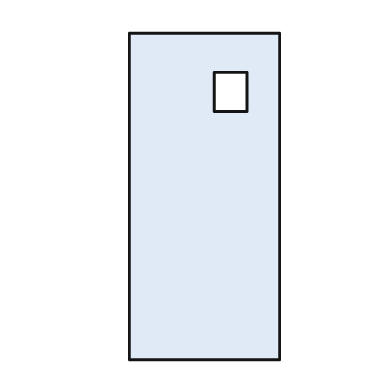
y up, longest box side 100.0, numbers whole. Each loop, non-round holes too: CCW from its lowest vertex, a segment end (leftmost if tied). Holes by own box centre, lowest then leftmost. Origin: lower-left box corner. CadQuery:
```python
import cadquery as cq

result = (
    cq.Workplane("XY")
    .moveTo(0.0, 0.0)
    .lineTo(46.0, 0.0)
    .lineTo(46.0, 100.0)
    .lineTo(0.0, 100.0)
    .close()
    .moveTo(26.0, 76.0)
    .lineTo(36.0, 76.0)
    .lineTo(36.0, 88.0)
    .lineTo(26.0, 88.0)
    .close()
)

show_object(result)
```